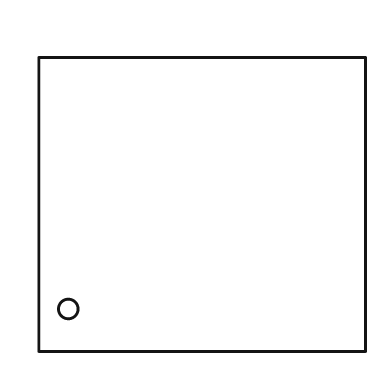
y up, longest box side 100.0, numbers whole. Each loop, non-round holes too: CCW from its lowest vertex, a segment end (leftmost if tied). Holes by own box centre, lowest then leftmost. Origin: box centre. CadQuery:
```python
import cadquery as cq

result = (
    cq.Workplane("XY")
    .moveTo(-50.0, -45.0)
    .lineTo(50.0, -45.0)
    .lineTo(50.0, 45.0)
    .lineTo(-50.0, 45.0)
    .close()
    .moveTo(-41.0, -32.0)
    .circle(3.0)
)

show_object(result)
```